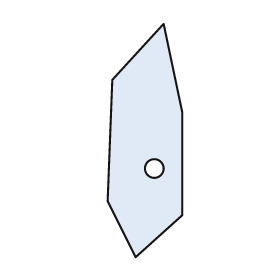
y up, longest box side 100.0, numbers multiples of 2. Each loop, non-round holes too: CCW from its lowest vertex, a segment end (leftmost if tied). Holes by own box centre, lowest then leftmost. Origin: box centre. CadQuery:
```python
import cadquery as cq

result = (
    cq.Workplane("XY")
    .moveTo(-4.0, -50.0)
    .lineTo(16.0, -32.0)
    .lineTo(16.0, 12.0)
    .lineTo(8.0, 50.0)
    .lineTo(-14.0, 26.0)
    .lineTo(-16.0, -26.0)
    .close()
    .moveTo(4.0, -12.0)
    .circle(4.0)
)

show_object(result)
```